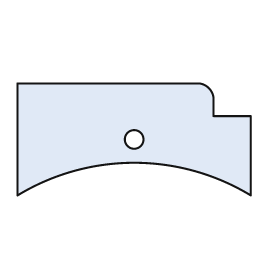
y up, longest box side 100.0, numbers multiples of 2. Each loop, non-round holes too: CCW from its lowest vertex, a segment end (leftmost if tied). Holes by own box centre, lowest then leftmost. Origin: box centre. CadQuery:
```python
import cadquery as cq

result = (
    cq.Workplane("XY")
    .moveTo(-50.0, -24.0)
    .threePointArc((0.0, -10.0), (50.0, -24.0))
    .lineTo(50.0, 10.0)
    .lineTo(34.0, 10.0)
    .lineTo(34.0, 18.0)
    .threePointArc((32.0, 22.0), (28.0, 24.0))
    .lineTo(-50.0, 24.0)
    .close()
    .moveTo(0.0, 0.0)
    .circle(4.0)
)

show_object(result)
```